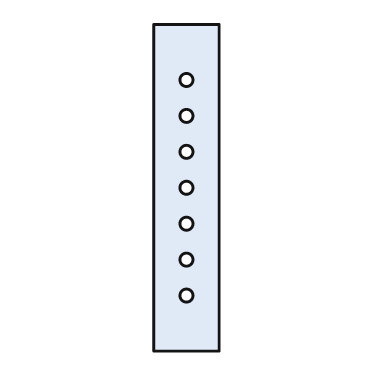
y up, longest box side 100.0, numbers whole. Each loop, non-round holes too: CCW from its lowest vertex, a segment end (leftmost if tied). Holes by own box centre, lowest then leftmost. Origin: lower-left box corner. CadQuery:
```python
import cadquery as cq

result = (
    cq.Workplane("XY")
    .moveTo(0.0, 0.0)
    .lineTo(20.0, 0.0)
    .lineTo(20.0, 100.0)
    .lineTo(0.0, 100.0)
    .close()
    .moveTo(10.0, 17.0)
    .circle(2.0)
    .moveTo(10.0, 28.0)
    .circle(2.0)
    .moveTo(10.0, 39.0)
    .circle(2.0)
    .moveTo(10.0, 50.0)
    .circle(2.0)
    .moveTo(10.0, 61.0)
    .circle(2.0)
    .moveTo(10.0, 72.0)
    .circle(2.0)
    .moveTo(10.0, 83.0)
    .circle(2.0)
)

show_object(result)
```